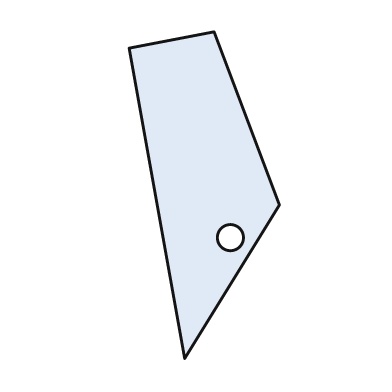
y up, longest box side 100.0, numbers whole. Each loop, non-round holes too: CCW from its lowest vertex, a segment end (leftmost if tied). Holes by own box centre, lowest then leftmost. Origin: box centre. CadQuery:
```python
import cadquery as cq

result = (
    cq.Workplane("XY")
    .moveTo(-6.0, -50.0)
    .lineTo(23.0, -3.0)
    .lineTo(3.0, 50.0)
    .lineTo(-23.0, 45.0)
    .close()
    .moveTo(8.0, -13.0)
    .circle(4.0)
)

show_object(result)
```